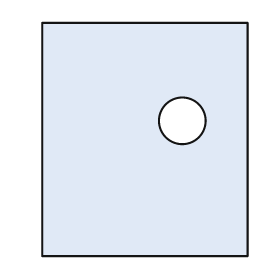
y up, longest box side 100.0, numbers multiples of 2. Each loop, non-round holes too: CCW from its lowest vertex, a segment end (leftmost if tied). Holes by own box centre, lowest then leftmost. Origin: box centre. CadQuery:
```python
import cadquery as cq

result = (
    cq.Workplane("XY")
    .moveTo(-44.0, -50.0)
    .lineTo(44.0, -50.0)
    .lineTo(44.0, 50.0)
    .lineTo(-44.0, 50.0)
    .close()
    .moveTo(16.0, 8.0)
    .circle(10.0)
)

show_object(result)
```